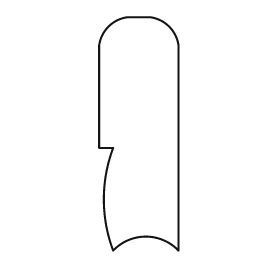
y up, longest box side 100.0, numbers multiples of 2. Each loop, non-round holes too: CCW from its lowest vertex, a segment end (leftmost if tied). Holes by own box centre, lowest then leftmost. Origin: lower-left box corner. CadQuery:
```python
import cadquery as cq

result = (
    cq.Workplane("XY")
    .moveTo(6.0, 0.0)
    .threePointArc((20.0, 6.0), (34.0, 0.0))
    .lineTo(34.0, 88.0)
    .threePointArc((30.0, 96.0), (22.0, 100.0))
    .lineTo(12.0, 100.0)
    .threePointArc((4.0, 96.0), (0.0, 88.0))
    .lineTo(0.0, 44.0)
    .lineTo(6.0, 44.0)
    .threePointArc((2.0, 22.0), (6.0, 0.0))
    .close()
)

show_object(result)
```